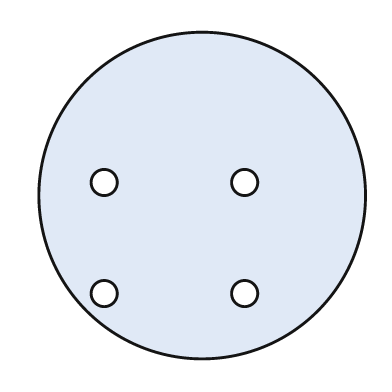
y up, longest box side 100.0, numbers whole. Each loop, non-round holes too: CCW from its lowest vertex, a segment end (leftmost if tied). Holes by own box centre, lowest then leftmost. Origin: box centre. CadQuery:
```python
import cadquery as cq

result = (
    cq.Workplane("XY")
    .moveTo(0.0, 0.0)
    .circle(50.0)
    .moveTo(-30.0, -30.0)
    .circle(4.0)
    .moveTo(13.0, -30.0)
    .circle(4.0)
    .moveTo(-30.0, 4.0)
    .circle(4.0)
    .moveTo(13.0, 4.0)
    .circle(4.0)
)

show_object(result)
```